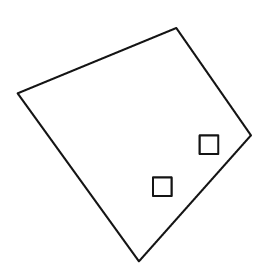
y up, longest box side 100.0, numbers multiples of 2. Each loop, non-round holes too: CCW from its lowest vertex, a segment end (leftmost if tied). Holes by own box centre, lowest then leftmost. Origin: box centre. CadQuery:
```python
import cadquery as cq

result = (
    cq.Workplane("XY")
    .moveTo(2.0, -50.0)
    .lineTo(50.0, 4.0)
    .lineTo(18.0, 50.0)
    .lineTo(-50.0, 22.0)
    .close()
    .moveTo(8.0, -22.0)
    .lineTo(16.0, -22.0)
    .lineTo(16.0, -14.0)
    .lineTo(8.0, -14.0)
    .close()
    .moveTo(28.0, -4.0)
    .lineTo(36.0, -4.0)
    .lineTo(36.0, 4.0)
    .lineTo(28.0, 4.0)
    .close()
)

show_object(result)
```